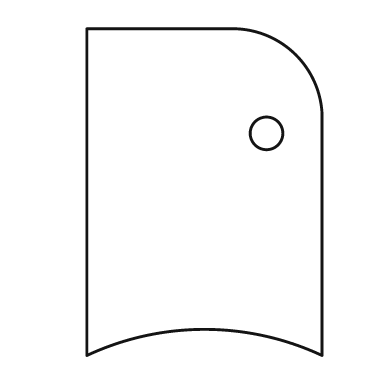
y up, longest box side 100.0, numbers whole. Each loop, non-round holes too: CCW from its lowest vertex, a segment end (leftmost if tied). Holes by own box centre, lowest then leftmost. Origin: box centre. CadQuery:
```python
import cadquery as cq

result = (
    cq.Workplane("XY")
    .moveTo(-36.0, -50.0)
    .threePointArc((0.0, -42.0), (36.0, -50.0))
    .lineTo(36.0, 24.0)
    .threePointArc((28.0, 42.0), (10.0, 50.0))
    .lineTo(-36.0, 50.0)
    .close()
    .moveTo(19.0, 18.0)
    .circle(5.0)
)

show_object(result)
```